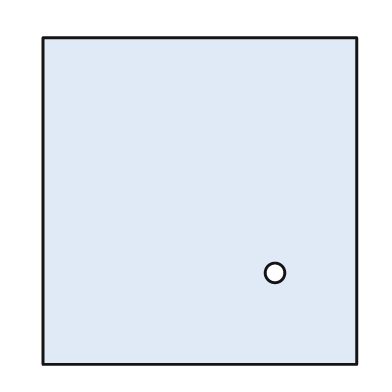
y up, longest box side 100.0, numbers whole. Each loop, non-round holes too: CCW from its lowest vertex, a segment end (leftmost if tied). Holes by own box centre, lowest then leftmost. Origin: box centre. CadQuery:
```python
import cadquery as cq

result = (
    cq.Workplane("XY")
    .moveTo(-48.0, -50.0)
    .lineTo(48.0, -50.0)
    .lineTo(48.0, 50.0)
    .lineTo(-48.0, 50.0)
    .close()
    .moveTo(23.0, -22.0)
    .circle(3.0)
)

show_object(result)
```